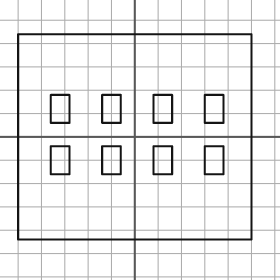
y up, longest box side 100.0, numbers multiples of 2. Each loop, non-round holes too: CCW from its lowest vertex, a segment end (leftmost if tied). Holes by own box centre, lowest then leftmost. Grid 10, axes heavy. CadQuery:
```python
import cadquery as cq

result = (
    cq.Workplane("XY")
    .moveTo(-50.0, -44.0)
    .lineTo(50.0, -44.0)
    .lineTo(50.0, 44.0)
    .lineTo(-50.0, 44.0)
    .close()
    .moveTo(-36.0, -16.0)
    .lineTo(-28.0, -16.0)
    .lineTo(-28.0, -4.0)
    .lineTo(-36.0, -4.0)
    .close()
    .moveTo(-14.0, -16.0)
    .lineTo(-6.0, -16.0)
    .lineTo(-6.0, -4.0)
    .lineTo(-14.0, -4.0)
    .close()
    .moveTo(8.0, -16.0)
    .lineTo(16.0, -16.0)
    .lineTo(16.0, -4.0)
    .lineTo(8.0, -4.0)
    .close()
    .moveTo(30.0, -16.0)
    .lineTo(38.0, -16.0)
    .lineTo(38.0, -4.0)
    .lineTo(30.0, -4.0)
    .close()
    .moveTo(-36.0, 6.0)
    .lineTo(-28.0, 6.0)
    .lineTo(-28.0, 18.0)
    .lineTo(-36.0, 18.0)
    .close()
    .moveTo(-14.0, 6.0)
    .lineTo(-6.0, 6.0)
    .lineTo(-6.0, 18.0)
    .lineTo(-14.0, 18.0)
    .close()
    .moveTo(8.0, 6.0)
    .lineTo(16.0, 6.0)
    .lineTo(16.0, 18.0)
    .lineTo(8.0, 18.0)
    .close()
    .moveTo(30.0, 6.0)
    .lineTo(38.0, 6.0)
    .lineTo(38.0, 18.0)
    .lineTo(30.0, 18.0)
    .close()
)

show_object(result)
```